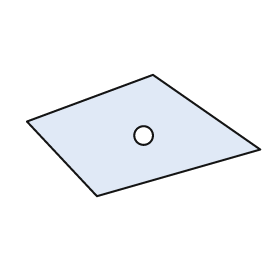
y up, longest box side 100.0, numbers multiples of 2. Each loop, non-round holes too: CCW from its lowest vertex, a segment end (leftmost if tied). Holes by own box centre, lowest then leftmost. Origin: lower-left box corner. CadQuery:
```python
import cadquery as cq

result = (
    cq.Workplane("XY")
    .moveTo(30.0, 0.0)
    .lineTo(100.0, 20.0)
    .lineTo(54.0, 52.0)
    .lineTo(0.0, 32.0)
    .close()
    .moveTo(50.0, 26.0)
    .circle(4.0)
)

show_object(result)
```